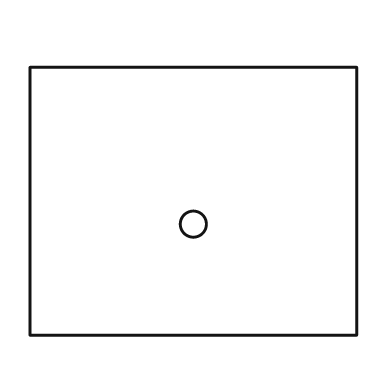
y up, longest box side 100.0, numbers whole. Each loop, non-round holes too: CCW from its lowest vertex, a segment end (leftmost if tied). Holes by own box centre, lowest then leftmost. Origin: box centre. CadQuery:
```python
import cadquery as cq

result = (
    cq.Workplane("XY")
    .moveTo(-50.0, -41.0)
    .lineTo(50.0, -41.0)
    .lineTo(50.0, 41.0)
    .lineTo(-50.0, 41.0)
    .close()
    .moveTo(0.0, -7.0)
    .circle(4.0)
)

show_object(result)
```